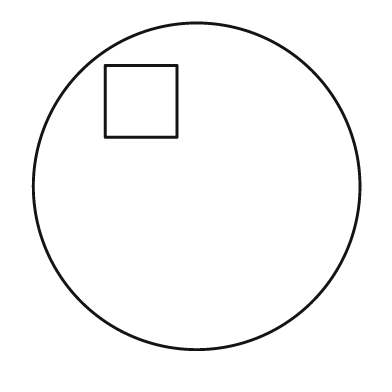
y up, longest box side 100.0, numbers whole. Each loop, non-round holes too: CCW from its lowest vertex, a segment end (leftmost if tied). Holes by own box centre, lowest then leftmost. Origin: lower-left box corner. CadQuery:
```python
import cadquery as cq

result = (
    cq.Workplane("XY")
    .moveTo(50.0, 50.0)
    .circle(50.0)
    .moveTo(22.0, 65.0)
    .lineTo(44.0, 65.0)
    .lineTo(44.0, 87.0)
    .lineTo(22.0, 87.0)
    .close()
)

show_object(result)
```